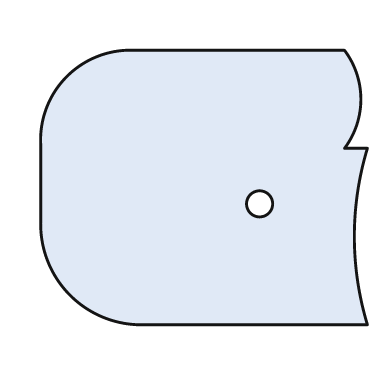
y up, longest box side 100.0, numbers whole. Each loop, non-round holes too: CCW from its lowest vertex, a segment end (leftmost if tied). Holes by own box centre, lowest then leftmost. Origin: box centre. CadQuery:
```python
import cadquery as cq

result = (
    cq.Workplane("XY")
    .moveTo(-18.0, -42.0)
    .lineTo(50.0, -42.0)
    .threePointArc((46.0, -15.0), (50.0, 12.0))
    .lineTo(43.0, 12.0)
    .threePointArc((48.0, 27.0), (43.0, 42.0))
    .lineTo(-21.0, 42.0)
    .threePointArc((-42.0, 34.0), (-50.0, 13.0))
    .lineTo(-50.0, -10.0)
    .threePointArc((-41.0, -33.0), (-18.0, -42.0))
    .close()
    .moveTo(17.0, -5.0)
    .circle(4.0)
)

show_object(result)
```